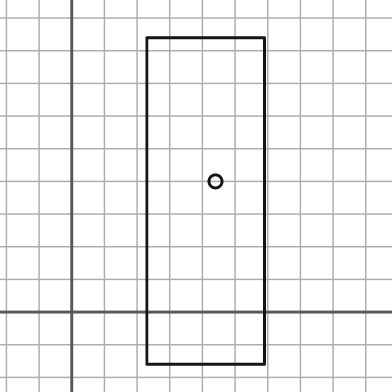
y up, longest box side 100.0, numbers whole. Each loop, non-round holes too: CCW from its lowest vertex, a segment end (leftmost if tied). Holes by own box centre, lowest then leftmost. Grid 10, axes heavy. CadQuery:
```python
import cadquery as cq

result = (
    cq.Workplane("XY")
    .moveTo(23.0, -16.0)
    .lineTo(59.0, -16.0)
    .lineTo(59.0, 84.0)
    .lineTo(23.0, 84.0)
    .close()
    .moveTo(44.0, 40.0)
    .circle(2.0)
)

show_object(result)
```